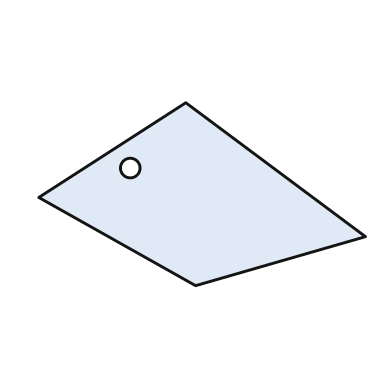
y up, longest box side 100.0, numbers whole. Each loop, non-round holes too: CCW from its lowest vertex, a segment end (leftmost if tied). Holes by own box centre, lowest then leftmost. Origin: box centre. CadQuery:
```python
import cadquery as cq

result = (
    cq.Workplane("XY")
    .moveTo(-2.0, -28.0)
    .lineTo(50.0, -13.0)
    .lineTo(-5.0, 28.0)
    .lineTo(-50.0, -1.0)
    .close()
    .moveTo(-22.0, 8.0)
    .circle(3.0)
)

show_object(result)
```